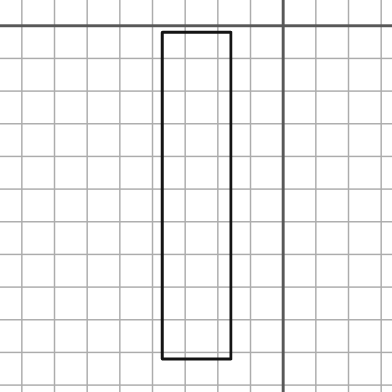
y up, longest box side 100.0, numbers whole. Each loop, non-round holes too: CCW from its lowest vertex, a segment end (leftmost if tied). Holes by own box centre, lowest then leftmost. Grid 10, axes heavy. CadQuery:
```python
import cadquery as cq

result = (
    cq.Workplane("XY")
    .moveTo(-37.0, -102.0)
    .lineTo(-16.0, -102.0)
    .lineTo(-16.0, -2.0)
    .lineTo(-37.0, -2.0)
    .close()
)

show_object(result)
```